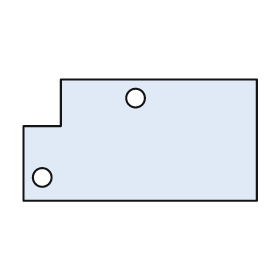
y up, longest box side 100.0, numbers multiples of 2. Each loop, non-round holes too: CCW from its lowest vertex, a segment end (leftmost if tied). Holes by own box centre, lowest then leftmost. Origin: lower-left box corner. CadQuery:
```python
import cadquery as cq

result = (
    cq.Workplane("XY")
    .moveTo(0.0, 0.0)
    .lineTo(100.0, 0.0)
    .lineTo(100.0, 52.0)
    .lineTo(16.0, 52.0)
    .lineTo(16.0, 32.0)
    .lineTo(0.0, 32.0)
    .close()
    .moveTo(8.0, 10.0)
    .circle(4.0)
    .moveTo(48.0, 44.0)
    .circle(4.0)
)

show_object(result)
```